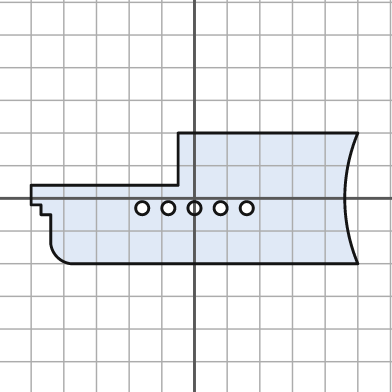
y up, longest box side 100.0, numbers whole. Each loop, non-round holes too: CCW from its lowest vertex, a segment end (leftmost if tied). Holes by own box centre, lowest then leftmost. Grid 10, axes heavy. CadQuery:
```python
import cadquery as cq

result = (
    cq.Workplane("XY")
    .moveTo(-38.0, -20.0)
    .lineTo(50.0, -20.0)
    .threePointArc((46.0, 0.0), (50.0, 20.0))
    .lineTo(-5.0, 20.0)
    .lineTo(-5.0, 4.0)
    .lineTo(-50.0, 4.0)
    .lineTo(-50.0, -2.0)
    .lineTo(-47.0, -2.0)
    .lineTo(-47.0, -5.0)
    .lineTo(-44.0, -5.0)
    .lineTo(-44.0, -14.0)
    .threePointArc((-42.0, -18.0), (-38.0, -20.0))
    .close()
    .moveTo(-16.0, -3.0)
    .circle(2.0)
    .moveTo(-8.0, -3.0)
    .circle(2.0)
    .moveTo(0.0, -3.0)
    .circle(2.0)
    .moveTo(8.0, -3.0)
    .circle(2.0)
    .moveTo(16.0, -3.0)
    .circle(2.0)
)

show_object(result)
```